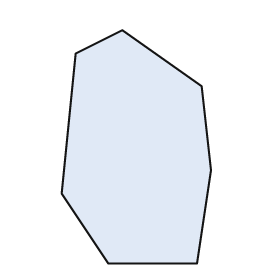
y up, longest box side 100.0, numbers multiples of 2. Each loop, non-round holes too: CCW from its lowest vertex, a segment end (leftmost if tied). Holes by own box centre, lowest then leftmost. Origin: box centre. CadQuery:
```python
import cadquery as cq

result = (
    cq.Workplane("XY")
    .moveTo(-12.0, -50.0)
    .lineTo(26.0, -50.0)
    .lineTo(32.0, -10.0)
    .lineTo(28.0, 26.0)
    .lineTo(-6.0, 50.0)
    .lineTo(-26.0, 40.0)
    .lineTo(-32.0, -20.0)
    .close()
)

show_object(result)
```